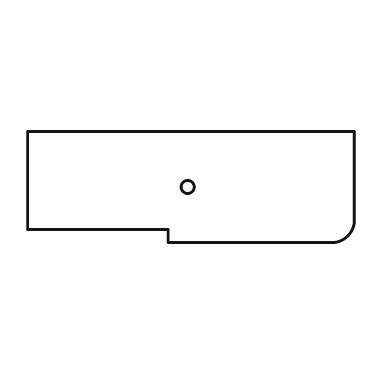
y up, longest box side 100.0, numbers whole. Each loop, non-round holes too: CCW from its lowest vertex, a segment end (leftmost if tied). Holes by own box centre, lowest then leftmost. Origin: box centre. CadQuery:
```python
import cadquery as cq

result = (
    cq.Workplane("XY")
    .moveTo(-7.0, -17.0)
    .lineTo(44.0, -17.0)
    .threePointArc((48.0, -15.0), (50.0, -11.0))
    .lineTo(50.0, 17.0)
    .lineTo(-50.0, 17.0)
    .lineTo(-50.0, -13.0)
    .lineTo(-7.0, -13.0)
    .close()
    .moveTo(-1.0, 0.0)
    .circle(2.0)
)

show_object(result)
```